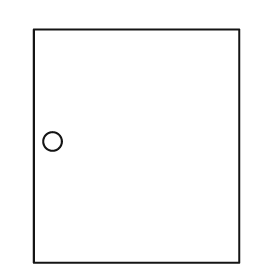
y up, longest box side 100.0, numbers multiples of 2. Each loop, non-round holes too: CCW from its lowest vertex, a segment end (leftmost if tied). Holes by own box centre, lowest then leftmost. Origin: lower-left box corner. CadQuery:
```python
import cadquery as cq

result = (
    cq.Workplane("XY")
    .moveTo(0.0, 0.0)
    .lineTo(88.0, 0.0)
    .lineTo(88.0, 100.0)
    .lineTo(0.0, 100.0)
    .close()
    .moveTo(8.0, 52.0)
    .circle(4.0)
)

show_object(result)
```